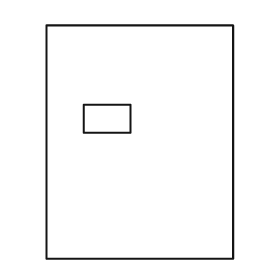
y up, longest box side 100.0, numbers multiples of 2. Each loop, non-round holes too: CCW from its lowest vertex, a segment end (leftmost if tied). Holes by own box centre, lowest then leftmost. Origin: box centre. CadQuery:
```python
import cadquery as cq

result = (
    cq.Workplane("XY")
    .moveTo(-40.0, -50.0)
    .lineTo(40.0, -50.0)
    .lineTo(40.0, 50.0)
    .lineTo(-40.0, 50.0)
    .close()
    .moveTo(-24.0, 4.0)
    .lineTo(-4.0, 4.0)
    .lineTo(-4.0, 16.0)
    .lineTo(-24.0, 16.0)
    .close()
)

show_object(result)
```